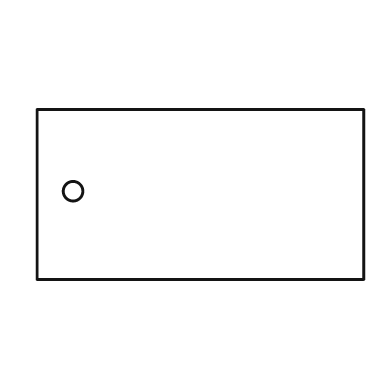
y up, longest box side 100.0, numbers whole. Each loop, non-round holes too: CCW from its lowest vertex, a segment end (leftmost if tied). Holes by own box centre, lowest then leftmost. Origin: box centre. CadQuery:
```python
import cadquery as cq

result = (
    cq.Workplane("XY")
    .moveTo(-50.0, -26.0)
    .lineTo(50.0, -26.0)
    .lineTo(50.0, 26.0)
    .lineTo(-50.0, 26.0)
    .close()
    .moveTo(-39.0, 1.0)
    .circle(3.0)
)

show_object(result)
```